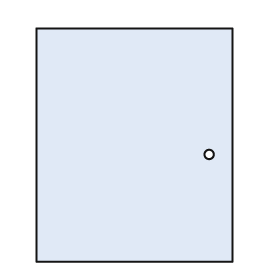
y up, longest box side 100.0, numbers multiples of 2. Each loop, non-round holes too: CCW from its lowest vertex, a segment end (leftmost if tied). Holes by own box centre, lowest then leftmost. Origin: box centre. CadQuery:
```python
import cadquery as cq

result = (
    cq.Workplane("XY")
    .moveTo(-42.0, -50.0)
    .lineTo(42.0, -50.0)
    .lineTo(42.0, 50.0)
    .lineTo(-42.0, 50.0)
    .close()
    .moveTo(32.0, -4.0)
    .circle(2.0)
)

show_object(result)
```